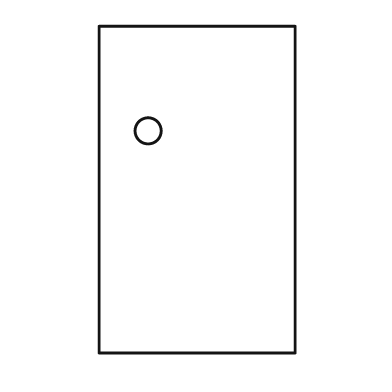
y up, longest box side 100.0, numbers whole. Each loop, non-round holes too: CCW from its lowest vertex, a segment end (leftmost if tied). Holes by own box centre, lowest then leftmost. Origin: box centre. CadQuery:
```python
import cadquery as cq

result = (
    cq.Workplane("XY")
    .moveTo(-30.0, -50.0)
    .lineTo(30.0, -50.0)
    .lineTo(30.0, 50.0)
    .lineTo(-30.0, 50.0)
    .close()
    .moveTo(-15.0, 18.0)
    .circle(4.0)
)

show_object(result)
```